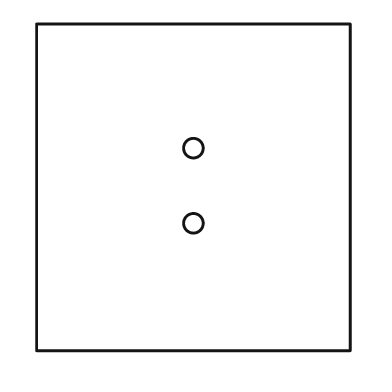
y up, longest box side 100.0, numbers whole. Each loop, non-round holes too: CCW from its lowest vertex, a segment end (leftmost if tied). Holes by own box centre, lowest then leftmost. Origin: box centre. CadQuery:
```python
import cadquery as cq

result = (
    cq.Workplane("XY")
    .moveTo(-48.0, -50.0)
    .lineTo(48.0, -50.0)
    .lineTo(48.0, 50.0)
    .lineTo(-48.0, 50.0)
    .close()
    .moveTo(0.0, -11.0)
    .circle(3.0)
    .moveTo(0.0, 12.0)
    .circle(3.0)
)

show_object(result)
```